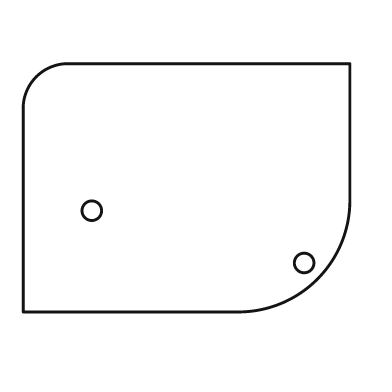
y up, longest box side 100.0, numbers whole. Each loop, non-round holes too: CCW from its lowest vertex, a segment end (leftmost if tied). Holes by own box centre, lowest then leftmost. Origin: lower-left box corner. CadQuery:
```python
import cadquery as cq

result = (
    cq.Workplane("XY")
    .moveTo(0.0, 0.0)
    .lineTo(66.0, 0.0)
    .threePointArc((90.0, 10.0), (100.0, 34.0))
    .lineTo(100.0, 76.0)
    .lineTo(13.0, 76.0)
    .threePointArc((4.0, 72.0), (0.0, 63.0))
    .close()
    .moveTo(86.0, 15.0)
    .circle(3.0)
    .moveTo(21.0, 31.0)
    .circle(3.0)
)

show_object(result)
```